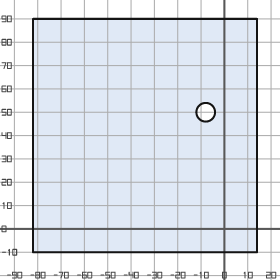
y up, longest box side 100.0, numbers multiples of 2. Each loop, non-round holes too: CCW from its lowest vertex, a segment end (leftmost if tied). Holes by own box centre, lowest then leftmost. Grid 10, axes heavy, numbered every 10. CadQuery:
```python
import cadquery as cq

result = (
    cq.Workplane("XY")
    .moveTo(-82.0, -10.0)
    .lineTo(14.0, -10.0)
    .lineTo(14.0, 90.0)
    .lineTo(-82.0, 90.0)
    .close()
    .moveTo(-8.0, 50.0)
    .circle(4.0)
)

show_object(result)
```